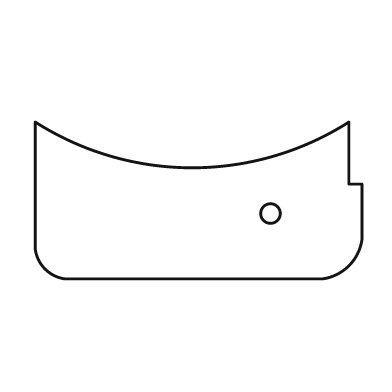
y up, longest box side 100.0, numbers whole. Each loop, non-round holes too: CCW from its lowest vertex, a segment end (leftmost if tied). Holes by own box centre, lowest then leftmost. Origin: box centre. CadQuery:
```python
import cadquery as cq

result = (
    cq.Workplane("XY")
    .moveTo(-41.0, -24.0)
    .lineTo(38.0, -24.0)
    .threePointArc((46.0, -20.0), (50.0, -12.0))
    .lineTo(50.0, 5.0)
    .lineTo(46.0, 5.0)
    .lineTo(46.0, 24.0)
    .threePointArc((-2.0, 10.0), (-50.0, 24.0))
    .lineTo(-50.0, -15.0)
    .threePointArc((-47.0, -21.0), (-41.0, -24.0))
    .close()
    .moveTo(22.0, -4.0)
    .circle(3.0)
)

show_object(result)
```